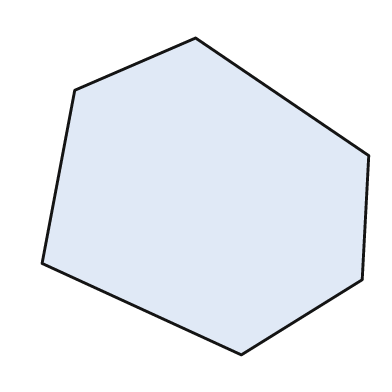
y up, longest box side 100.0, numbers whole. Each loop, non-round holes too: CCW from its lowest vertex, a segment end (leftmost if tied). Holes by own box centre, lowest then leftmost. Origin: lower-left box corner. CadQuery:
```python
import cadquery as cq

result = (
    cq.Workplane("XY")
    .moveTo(61.0, 0.0)
    .lineTo(98.0, 23.0)
    .lineTo(100.0, 61.0)
    .lineTo(47.0, 97.0)
    .lineTo(10.0, 81.0)
    .lineTo(0.0, 28.0)
    .close()
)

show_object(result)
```